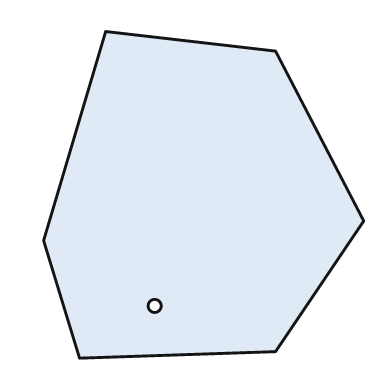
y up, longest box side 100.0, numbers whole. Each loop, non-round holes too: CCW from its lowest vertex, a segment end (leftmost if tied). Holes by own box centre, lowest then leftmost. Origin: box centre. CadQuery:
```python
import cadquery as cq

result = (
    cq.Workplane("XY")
    .moveTo(-38.0, -50.0)
    .lineTo(22.0, -48.0)
    .lineTo(49.0, -8.0)
    .lineTo(22.0, 44.0)
    .lineTo(-30.0, 50.0)
    .lineTo(-49.0, -14.0)
    .close()
    .moveTo(-15.0, -34.0)
    .circle(2.0)
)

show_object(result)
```